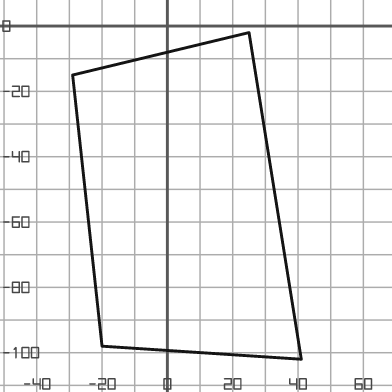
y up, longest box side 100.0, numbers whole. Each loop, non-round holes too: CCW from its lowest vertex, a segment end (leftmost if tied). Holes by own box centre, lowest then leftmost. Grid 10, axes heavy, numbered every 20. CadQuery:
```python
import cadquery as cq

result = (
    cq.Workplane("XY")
    .moveTo(41.0, -102.0)
    .lineTo(25.0, -2.0)
    .lineTo(-29.0, -15.0)
    .lineTo(-20.0, -98.0)
    .close()
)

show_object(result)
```